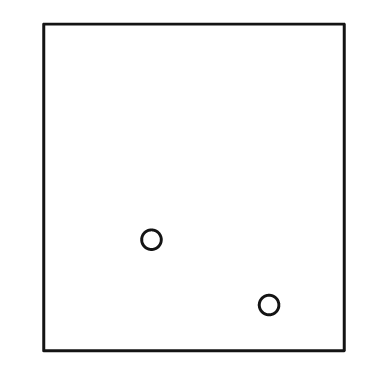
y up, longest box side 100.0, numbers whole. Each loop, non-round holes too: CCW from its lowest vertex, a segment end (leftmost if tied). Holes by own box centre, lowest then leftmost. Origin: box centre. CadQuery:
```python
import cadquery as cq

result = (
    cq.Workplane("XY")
    .moveTo(-46.0, -50.0)
    .lineTo(46.0, -50.0)
    .lineTo(46.0, 50.0)
    .lineTo(-46.0, 50.0)
    .close()
    .moveTo(23.0, -36.0)
    .circle(3.0)
    .moveTo(-13.0, -16.0)
    .circle(3.0)
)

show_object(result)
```